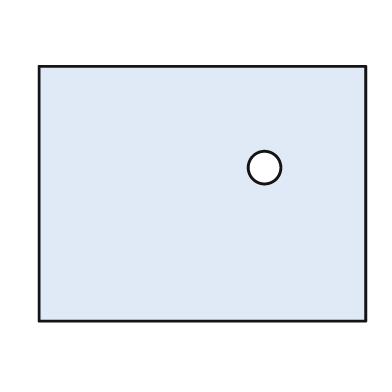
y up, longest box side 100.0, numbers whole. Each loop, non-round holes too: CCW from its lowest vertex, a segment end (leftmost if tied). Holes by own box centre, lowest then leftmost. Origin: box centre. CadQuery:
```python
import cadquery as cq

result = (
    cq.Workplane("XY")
    .moveTo(-50.0, -39.0)
    .lineTo(50.0, -39.0)
    .lineTo(50.0, 39.0)
    .lineTo(-50.0, 39.0)
    .close()
    .moveTo(19.0, 8.0)
    .circle(5.0)
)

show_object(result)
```